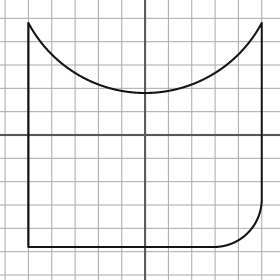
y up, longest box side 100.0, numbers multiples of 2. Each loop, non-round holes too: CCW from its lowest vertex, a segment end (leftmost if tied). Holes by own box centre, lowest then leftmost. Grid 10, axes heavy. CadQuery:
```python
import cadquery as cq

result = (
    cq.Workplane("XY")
    .moveTo(-50.0, -48.0)
    .lineTo(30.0, -48.0)
    .threePointArc((44.0, -42.0), (50.0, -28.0))
    .lineTo(50.0, 48.0)
    .threePointArc((0.0, 18.0), (-50.0, 48.0))
    .close()
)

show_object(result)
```